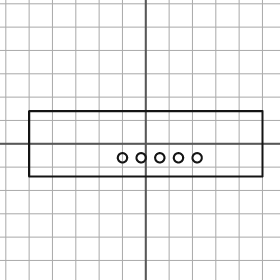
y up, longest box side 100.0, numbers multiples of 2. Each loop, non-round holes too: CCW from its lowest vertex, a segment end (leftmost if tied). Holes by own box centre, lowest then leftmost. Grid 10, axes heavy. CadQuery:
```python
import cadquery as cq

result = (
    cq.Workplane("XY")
    .moveTo(-50.0, -14.0)
    .lineTo(50.0, -14.0)
    .lineTo(50.0, 14.0)
    .lineTo(-50.0, 14.0)
    .close()
    .moveTo(-10.0, -6.0)
    .circle(2.0)
    .moveTo(-2.0, -6.0)
    .circle(2.0)
    .moveTo(6.0, -6.0)
    .circle(2.0)
    .moveTo(14.0, -6.0)
    .circle(2.0)
    .moveTo(22.0, -6.0)
    .circle(2.0)
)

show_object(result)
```